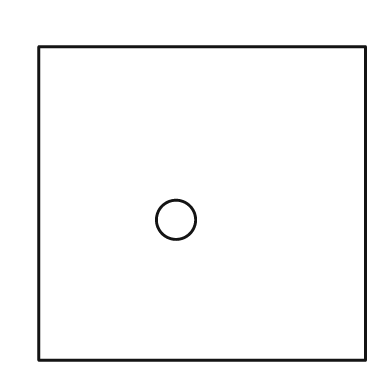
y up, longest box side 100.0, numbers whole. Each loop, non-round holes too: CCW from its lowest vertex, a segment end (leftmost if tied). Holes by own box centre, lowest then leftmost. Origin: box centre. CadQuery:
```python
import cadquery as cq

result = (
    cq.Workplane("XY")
    .moveTo(-50.0, -48.0)
    .lineTo(50.0, -48.0)
    .lineTo(50.0, 48.0)
    .lineTo(-50.0, 48.0)
    .close()
    .moveTo(-8.0, -5.0)
    .circle(6.0)
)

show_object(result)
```